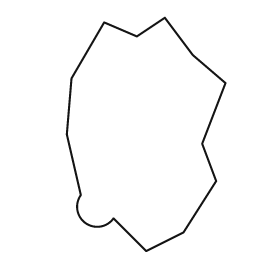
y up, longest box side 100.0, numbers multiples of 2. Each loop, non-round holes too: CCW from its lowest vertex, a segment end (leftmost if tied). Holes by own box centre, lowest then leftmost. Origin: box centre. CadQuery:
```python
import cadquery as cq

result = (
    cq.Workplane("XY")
    .moveTo(0.0, -50.0)
    .lineTo(16.0, -42.0)
    .lineTo(30.0, -20.0)
    .lineTo(24.0, -4.0)
    .lineTo(34.0, 22.0)
    .lineTo(20.0, 34.0)
    .lineTo(8.0, 50.0)
    .lineTo(-4.0, 42.0)
    .lineTo(-18.0, 48.0)
    .lineTo(-32.0, 24.0)
    .lineTo(-34.0, 0.0)
    .lineTo(-28.0, -26.0)
    .threePointArc((-26.0, -38.0), (-14.0, -36.0))
    .close()
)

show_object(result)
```